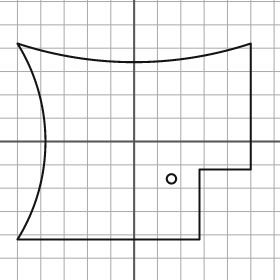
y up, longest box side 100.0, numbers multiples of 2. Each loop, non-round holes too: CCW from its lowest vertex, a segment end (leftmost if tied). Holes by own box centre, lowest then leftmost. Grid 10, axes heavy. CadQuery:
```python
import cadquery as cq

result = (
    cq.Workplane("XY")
    .moveTo(-50.0, -42.0)
    .lineTo(28.0, -42.0)
    .lineTo(28.0, -12.0)
    .lineTo(50.0, -12.0)
    .lineTo(50.0, 42.0)
    .threePointArc((0.0, 34.0), (-50.0, 42.0))
    .threePointArc((-38.0, 0.0), (-50.0, -42.0))
    .close()
    .moveTo(16.0, -16.0)
    .circle(2.0)
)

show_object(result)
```